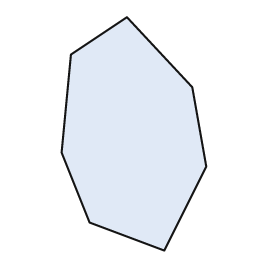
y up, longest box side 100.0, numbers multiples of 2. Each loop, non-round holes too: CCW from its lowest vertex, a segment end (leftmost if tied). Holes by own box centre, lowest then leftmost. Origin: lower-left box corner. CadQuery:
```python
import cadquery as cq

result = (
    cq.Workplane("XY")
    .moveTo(44.0, 0.0)
    .lineTo(62.0, 36.0)
    .lineTo(56.0, 70.0)
    .lineTo(28.0, 100.0)
    .lineTo(4.0, 84.0)
    .lineTo(0.0, 42.0)
    .lineTo(12.0, 12.0)
    .close()
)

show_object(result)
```